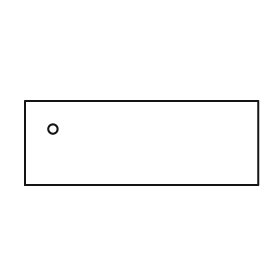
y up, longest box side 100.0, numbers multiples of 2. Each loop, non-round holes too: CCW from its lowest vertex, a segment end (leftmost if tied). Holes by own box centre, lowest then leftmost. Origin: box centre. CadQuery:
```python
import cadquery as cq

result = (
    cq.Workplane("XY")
    .moveTo(-50.0, -18.0)
    .lineTo(50.0, -18.0)
    .lineTo(50.0, 18.0)
    .lineTo(-50.0, 18.0)
    .close()
    .moveTo(-38.0, 6.0)
    .circle(2.0)
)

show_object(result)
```